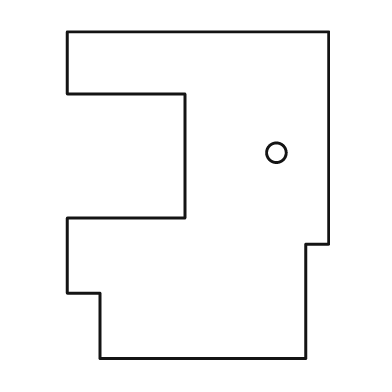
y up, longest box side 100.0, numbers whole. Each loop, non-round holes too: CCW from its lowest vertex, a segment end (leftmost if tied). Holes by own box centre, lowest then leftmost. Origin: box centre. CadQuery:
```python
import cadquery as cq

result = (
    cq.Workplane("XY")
    .moveTo(-30.0, -50.0)
    .lineTo(33.0, -50.0)
    .lineTo(33.0, -15.0)
    .lineTo(40.0, -15.0)
    .lineTo(40.0, 50.0)
    .lineTo(-40.0, 50.0)
    .lineTo(-40.0, 31.0)
    .lineTo(-4.0, 31.0)
    .lineTo(-4.0, -7.0)
    .lineTo(-40.0, -7.0)
    .lineTo(-40.0, -30.0)
    .lineTo(-30.0, -30.0)
    .close()
    .moveTo(24.0, 13.0)
    .circle(3.0)
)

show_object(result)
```